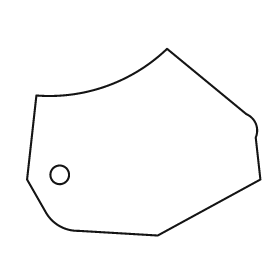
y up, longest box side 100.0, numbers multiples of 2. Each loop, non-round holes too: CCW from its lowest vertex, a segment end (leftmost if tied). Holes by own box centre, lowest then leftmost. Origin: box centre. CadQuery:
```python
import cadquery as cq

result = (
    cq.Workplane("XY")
    .moveTo(6.0, -40.0)
    .lineTo(50.0, -16.0)
    .lineTo(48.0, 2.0)
    .threePointArc((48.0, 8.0), (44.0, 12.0))
    .lineTo(10.0, 40.0)
    .threePointArc((-16.0, 24.0), (-46.0, 20.0))
    .lineTo(-50.0, -16.0)
    .lineTo(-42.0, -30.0)
    .threePointArc((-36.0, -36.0), (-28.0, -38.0))
    .close()
    .moveTo(-36.0, -14.0)
    .circle(4.0)
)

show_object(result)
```